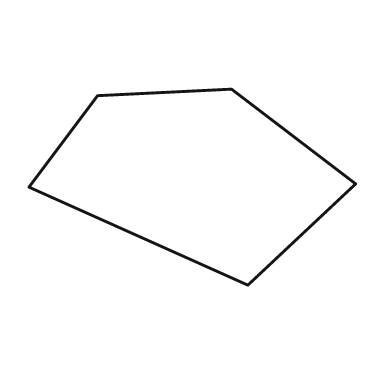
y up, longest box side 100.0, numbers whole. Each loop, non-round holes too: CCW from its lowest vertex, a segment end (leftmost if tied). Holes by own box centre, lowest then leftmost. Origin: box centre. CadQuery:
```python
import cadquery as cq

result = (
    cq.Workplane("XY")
    .moveTo(17.0, -30.0)
    .lineTo(50.0, 1.0)
    .lineTo(12.0, 30.0)
    .lineTo(-29.0, 28.0)
    .lineTo(-50.0, 0.0)
    .close()
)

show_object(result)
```